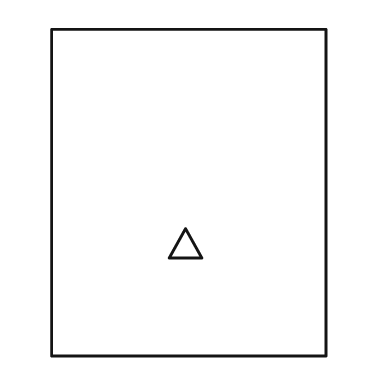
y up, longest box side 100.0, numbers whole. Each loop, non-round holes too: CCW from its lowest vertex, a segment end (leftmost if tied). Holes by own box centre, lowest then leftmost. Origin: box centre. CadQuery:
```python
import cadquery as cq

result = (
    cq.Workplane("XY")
    .moveTo(-42.0, -50.0)
    .lineTo(42.0, -50.0)
    .lineTo(42.0, 50.0)
    .lineTo(-42.0, 50.0)
    .close()
    .moveTo(-6.0, -20.0)
    .lineTo(4.0, -20.0)
    .lineTo(-1.0, -11.0)
    .close()
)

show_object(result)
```